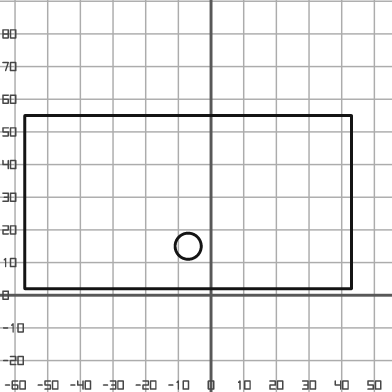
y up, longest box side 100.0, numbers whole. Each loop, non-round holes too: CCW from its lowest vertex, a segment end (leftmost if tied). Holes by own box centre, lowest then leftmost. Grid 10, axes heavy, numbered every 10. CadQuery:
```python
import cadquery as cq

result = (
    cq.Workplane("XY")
    .moveTo(-57.0, 2.0)
    .lineTo(43.0, 2.0)
    .lineTo(43.0, 55.0)
    .lineTo(-57.0, 55.0)
    .close()
    .moveTo(-7.0, 15.0)
    .circle(4.0)
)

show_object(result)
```